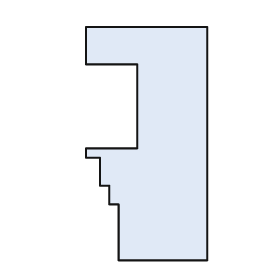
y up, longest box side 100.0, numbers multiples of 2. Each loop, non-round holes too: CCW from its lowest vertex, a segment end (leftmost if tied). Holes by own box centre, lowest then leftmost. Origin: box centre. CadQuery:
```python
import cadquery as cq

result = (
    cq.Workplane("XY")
    .moveTo(-12.0, -50.0)
    .lineTo(26.0, -50.0)
    .lineTo(26.0, 50.0)
    .lineTo(-26.0, 50.0)
    .lineTo(-26.0, 34.0)
    .lineTo(-4.0, 34.0)
    .lineTo(-4.0, -2.0)
    .lineTo(-26.0, -2.0)
    .lineTo(-26.0, -6.0)
    .lineTo(-20.0, -6.0)
    .lineTo(-20.0, -18.0)
    .lineTo(-16.0, -18.0)
    .lineTo(-16.0, -26.0)
    .lineTo(-12.0, -26.0)
    .close()
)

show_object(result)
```